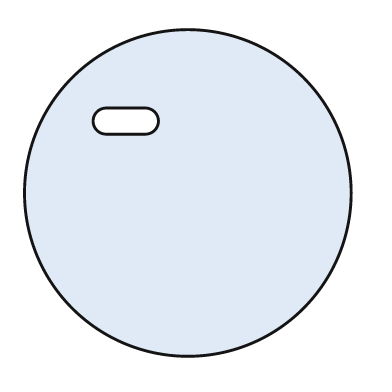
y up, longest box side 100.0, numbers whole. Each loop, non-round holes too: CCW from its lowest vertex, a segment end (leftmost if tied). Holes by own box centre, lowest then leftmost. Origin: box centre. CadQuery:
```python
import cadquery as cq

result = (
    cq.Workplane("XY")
    .moveTo(0.0, 0.0)
    .circle(50.0)
    .moveTo(-25.0, 18.0)
    .lineTo(-13.0, 18.0)
    .threePointArc((-9.0, 22.0), (-13.0, 26.0))
    .lineTo(-25.0, 26.0)
    .threePointArc((-29.0, 22.0), (-25.0, 18.0))
    .close()
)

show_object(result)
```